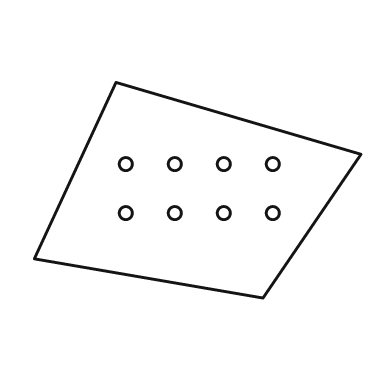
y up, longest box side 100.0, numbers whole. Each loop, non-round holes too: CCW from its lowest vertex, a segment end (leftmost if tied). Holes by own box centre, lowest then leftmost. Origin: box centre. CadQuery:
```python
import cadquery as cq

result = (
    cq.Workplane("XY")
    .moveTo(20.0, -33.0)
    .lineTo(50.0, 11.0)
    .lineTo(-25.0, 33.0)
    .lineTo(-50.0, -21.0)
    .close()
    .moveTo(-22.0, -7.0)
    .circle(2.0)
    .moveTo(-7.0, -7.0)
    .circle(2.0)
    .moveTo(8.0, -7.0)
    .circle(2.0)
    .moveTo(23.0, -7.0)
    .circle(2.0)
    .moveTo(-22.0, 8.0)
    .circle(2.0)
    .moveTo(-7.0, 8.0)
    .circle(2.0)
    .moveTo(8.0, 8.0)
    .circle(2.0)
    .moveTo(23.0, 8.0)
    .circle(2.0)
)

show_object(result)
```